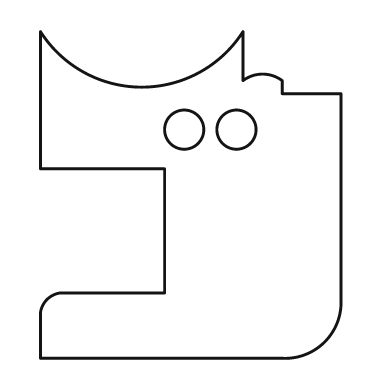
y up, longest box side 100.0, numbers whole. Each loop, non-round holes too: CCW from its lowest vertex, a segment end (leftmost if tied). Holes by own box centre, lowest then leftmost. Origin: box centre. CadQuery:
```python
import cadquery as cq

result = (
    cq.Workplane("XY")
    .moveTo(-46.0, -50.0)
    .lineTo(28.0, -50.0)
    .threePointArc((41.0, -45.0), (46.0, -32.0))
    .lineTo(46.0, 31.0)
    .lineTo(28.0, 31.0)
    .lineTo(28.0, 35.0)
    .threePointArc((22.0, 37.0), (16.0, 35.0))
    .lineTo(16.0, 50.0)
    .threePointArc((-15.0, 33.0), (-46.0, 50.0))
    .lineTo(-46.0, 8.0)
    .lineTo(-8.0, 8.0)
    .lineTo(-8.0, -30.0)
    .lineTo(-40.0, -30.0)
    .threePointArc((-44.0, -32.0), (-46.0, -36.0))
    .close()
    .moveTo(-2.0, 20.0)
    .circle(6.0)
    .moveTo(14.0, 20.0)
    .circle(6.0)
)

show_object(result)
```